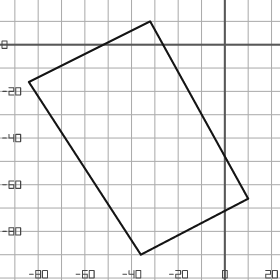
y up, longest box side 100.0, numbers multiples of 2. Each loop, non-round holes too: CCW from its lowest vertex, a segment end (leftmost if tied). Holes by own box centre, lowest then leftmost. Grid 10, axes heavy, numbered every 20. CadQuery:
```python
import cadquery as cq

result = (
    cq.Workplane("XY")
    .moveTo(-36.0, -90.0)
    .lineTo(10.0, -66.0)
    .lineTo(-32.0, 10.0)
    .lineTo(-84.0, -16.0)
    .close()
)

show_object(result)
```